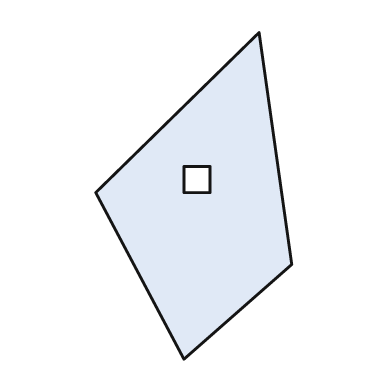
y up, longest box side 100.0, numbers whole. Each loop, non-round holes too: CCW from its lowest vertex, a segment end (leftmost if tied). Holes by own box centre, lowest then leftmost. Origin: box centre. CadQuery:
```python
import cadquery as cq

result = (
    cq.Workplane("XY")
    .moveTo(-3.0, -50.0)
    .lineTo(30.0, -21.0)
    .lineTo(20.0, 50.0)
    .lineTo(-30.0, 1.0)
    .close()
    .moveTo(-3.0, 1.0)
    .lineTo(5.0, 1.0)
    .lineTo(5.0, 9.0)
    .lineTo(-3.0, 9.0)
    .close()
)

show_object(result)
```